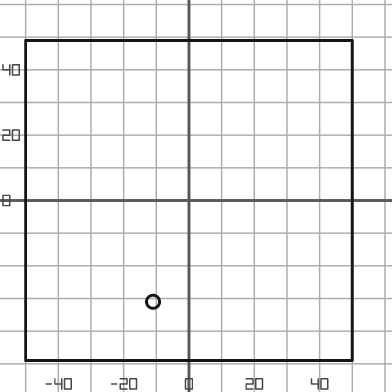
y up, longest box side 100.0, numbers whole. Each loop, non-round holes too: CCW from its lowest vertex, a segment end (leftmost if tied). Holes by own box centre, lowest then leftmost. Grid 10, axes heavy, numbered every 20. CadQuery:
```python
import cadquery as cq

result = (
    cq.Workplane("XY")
    .moveTo(-50.0, -49.0)
    .lineTo(50.0, -49.0)
    .lineTo(50.0, 49.0)
    .lineTo(-50.0, 49.0)
    .close()
    .moveTo(-11.0, -31.0)
    .circle(2.0)
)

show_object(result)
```